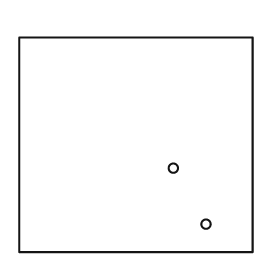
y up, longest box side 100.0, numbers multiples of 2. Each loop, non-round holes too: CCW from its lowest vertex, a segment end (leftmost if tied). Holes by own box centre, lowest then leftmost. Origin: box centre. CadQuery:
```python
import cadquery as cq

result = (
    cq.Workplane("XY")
    .moveTo(-50.0, -46.0)
    .lineTo(50.0, -46.0)
    .lineTo(50.0, 46.0)
    .lineTo(-50.0, 46.0)
    .close()
    .moveTo(30.0, -34.0)
    .circle(2.0)
    .moveTo(16.0, -10.0)
    .circle(2.0)
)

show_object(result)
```